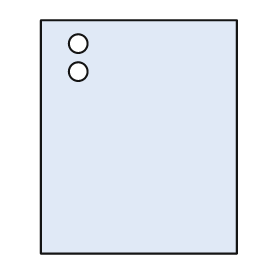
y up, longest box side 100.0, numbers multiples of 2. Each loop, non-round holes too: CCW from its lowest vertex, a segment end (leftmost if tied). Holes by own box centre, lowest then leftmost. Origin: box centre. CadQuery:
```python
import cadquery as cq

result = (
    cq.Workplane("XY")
    .moveTo(-42.0, -50.0)
    .lineTo(42.0, -50.0)
    .lineTo(42.0, 50.0)
    .lineTo(-42.0, 50.0)
    .close()
    .moveTo(-26.0, 28.0)
    .circle(4.0)
    .moveTo(-26.0, 40.0)
    .circle(4.0)
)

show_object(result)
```